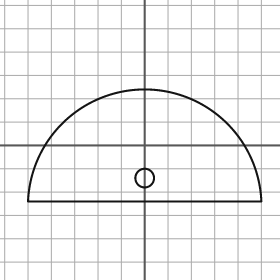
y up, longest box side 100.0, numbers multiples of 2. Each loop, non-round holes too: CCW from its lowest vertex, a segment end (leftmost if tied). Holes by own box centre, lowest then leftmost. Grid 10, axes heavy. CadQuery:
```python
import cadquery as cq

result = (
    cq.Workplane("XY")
    .moveTo(-50.0, -24.0)
    .lineTo(50.0, -24.0)
    .threePointArc((0.0, 24.0), (-50.0, -24.0))
    .close()
    .moveTo(0.0, -14.0)
    .circle(4.0)
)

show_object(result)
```